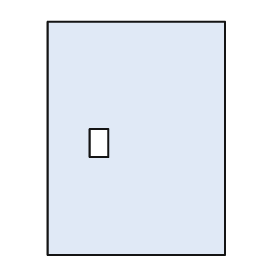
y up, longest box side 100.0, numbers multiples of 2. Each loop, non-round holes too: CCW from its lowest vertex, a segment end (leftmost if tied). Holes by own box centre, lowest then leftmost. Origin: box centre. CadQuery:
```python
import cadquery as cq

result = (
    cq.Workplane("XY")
    .moveTo(-38.0, -50.0)
    .lineTo(38.0, -50.0)
    .lineTo(38.0, 50.0)
    .lineTo(-38.0, 50.0)
    .close()
    .moveTo(-20.0, -8.0)
    .lineTo(-12.0, -8.0)
    .lineTo(-12.0, 4.0)
    .lineTo(-20.0, 4.0)
    .close()
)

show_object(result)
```